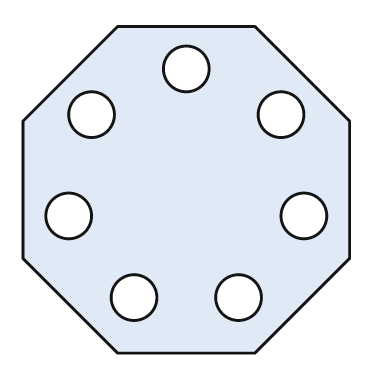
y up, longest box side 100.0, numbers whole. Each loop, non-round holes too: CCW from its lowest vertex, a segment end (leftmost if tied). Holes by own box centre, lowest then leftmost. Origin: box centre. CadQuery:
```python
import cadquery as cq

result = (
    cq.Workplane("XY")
    .moveTo(-21.0, -50.0)
    .lineTo(21.0, -50.0)
    .lineTo(50.0, -21.0)
    .lineTo(50.0, 21.0)
    .lineTo(21.0, 50.0)
    .lineTo(-21.0, 50.0)
    .lineTo(-50.0, 21.0)
    .lineTo(-50.0, -21.0)
    .close()
    .moveTo(-16.0, -33.0)
    .circle(7.0)
    .moveTo(16.0, -33.0)
    .circle(7.0)
    .moveTo(-36.0, -8.0)
    .circle(7.0)
    .moveTo(36.0, -8.0)
    .circle(7.0)
    .moveTo(-29.0, 23.0)
    .circle(7.0)
    .moveTo(29.0, 23.0)
    .circle(7.0)
    .moveTo(0.0, 37.0)
    .circle(7.0)
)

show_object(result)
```